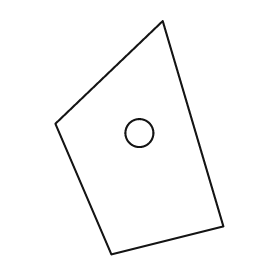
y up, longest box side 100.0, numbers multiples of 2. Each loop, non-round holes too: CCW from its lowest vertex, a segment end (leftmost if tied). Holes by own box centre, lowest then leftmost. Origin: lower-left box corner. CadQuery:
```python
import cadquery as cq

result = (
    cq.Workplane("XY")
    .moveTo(24.0, 0.0)
    .lineTo(72.0, 12.0)
    .lineTo(46.0, 100.0)
    .lineTo(0.0, 56.0)
    .close()
    .moveTo(36.0, 52.0)
    .circle(6.0)
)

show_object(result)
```